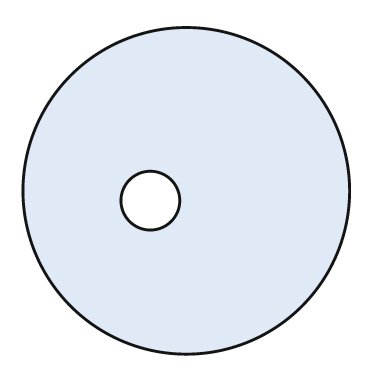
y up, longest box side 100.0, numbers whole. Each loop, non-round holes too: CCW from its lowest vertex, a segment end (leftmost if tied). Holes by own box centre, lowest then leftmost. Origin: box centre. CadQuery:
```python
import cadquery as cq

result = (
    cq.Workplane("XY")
    .moveTo(0.0, 0.0)
    .circle(50.0)
    .moveTo(-11.0, -3.0)
    .circle(9.0)
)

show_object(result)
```